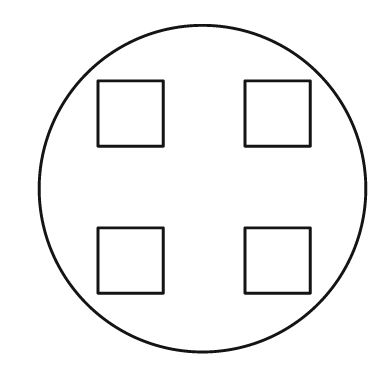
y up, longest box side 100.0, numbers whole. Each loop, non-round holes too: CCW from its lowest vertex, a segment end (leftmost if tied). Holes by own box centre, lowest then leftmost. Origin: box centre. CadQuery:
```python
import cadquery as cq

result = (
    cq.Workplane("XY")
    .moveTo(0.0, 0.0)
    .circle(50.0)
    .moveTo(-32.0, -32.0)
    .lineTo(-12.0, -32.0)
    .lineTo(-12.0, -12.0)
    .lineTo(-32.0, -12.0)
    .close()
    .moveTo(13.0, -32.0)
    .lineTo(33.0, -32.0)
    .lineTo(33.0, -12.0)
    .lineTo(13.0, -12.0)
    .close()
    .moveTo(-32.0, 13.0)
    .lineTo(-12.0, 13.0)
    .lineTo(-12.0, 33.0)
    .lineTo(-32.0, 33.0)
    .close()
    .moveTo(13.0, 13.0)
    .lineTo(33.0, 13.0)
    .lineTo(33.0, 33.0)
    .lineTo(13.0, 33.0)
    .close()
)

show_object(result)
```